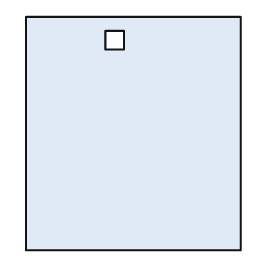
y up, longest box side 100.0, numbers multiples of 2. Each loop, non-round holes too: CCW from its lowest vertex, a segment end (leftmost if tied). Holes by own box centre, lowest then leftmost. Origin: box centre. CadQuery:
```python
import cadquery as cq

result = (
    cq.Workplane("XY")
    .moveTo(-46.0, -50.0)
    .lineTo(46.0, -50.0)
    .lineTo(46.0, 50.0)
    .lineTo(-46.0, 50.0)
    .close()
    .moveTo(-12.0, 36.0)
    .lineTo(-4.0, 36.0)
    .lineTo(-4.0, 44.0)
    .lineTo(-12.0, 44.0)
    .close()
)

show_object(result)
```